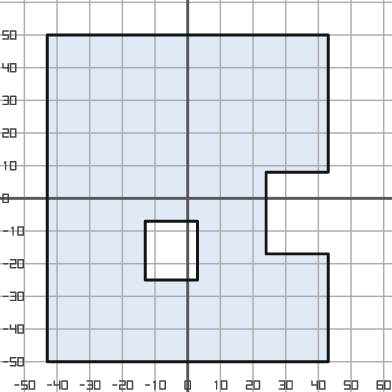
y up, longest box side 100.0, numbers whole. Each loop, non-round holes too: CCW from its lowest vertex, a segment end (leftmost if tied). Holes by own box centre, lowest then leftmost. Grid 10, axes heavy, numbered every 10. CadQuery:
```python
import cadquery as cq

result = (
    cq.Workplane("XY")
    .moveTo(-43.0, -50.0)
    .lineTo(43.0, -50.0)
    .lineTo(43.0, -17.0)
    .lineTo(24.0, -17.0)
    .lineTo(24.0, 8.0)
    .lineTo(43.0, 8.0)
    .lineTo(43.0, 50.0)
    .lineTo(-43.0, 50.0)
    .close()
    .moveTo(-13.0, -25.0)
    .lineTo(3.0, -25.0)
    .lineTo(3.0, -7.0)
    .lineTo(-13.0, -7.0)
    .close()
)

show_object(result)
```